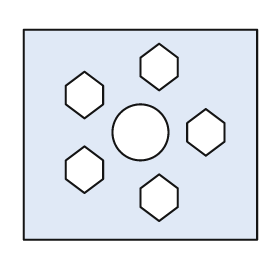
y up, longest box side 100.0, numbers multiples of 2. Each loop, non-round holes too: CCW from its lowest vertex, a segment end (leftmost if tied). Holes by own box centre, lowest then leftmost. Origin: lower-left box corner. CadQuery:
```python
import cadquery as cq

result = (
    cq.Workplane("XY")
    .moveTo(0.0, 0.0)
    .lineTo(100.0, 0.0)
    .lineTo(100.0, 90.0)
    .lineTo(0.0, 90.0)
    .close()
    .moveTo(58.0, 8.0)
    .lineTo(66.0, 14.0)
    .lineTo(66.0, 22.0)
    .lineTo(58.0, 28.0)
    .lineTo(50.0, 22.0)
    .lineTo(50.0, 14.0)
    .close()
    .moveTo(26.0, 20.0)
    .lineTo(34.0, 26.0)
    .lineTo(34.0, 34.0)
    .lineTo(26.0, 40.0)
    .lineTo(18.0, 34.0)
    .lineTo(18.0, 26.0)
    .close()
    .moveTo(50.0, 46.0)
    .circle(12.0)
    .moveTo(78.0, 36.0)
    .lineTo(86.0, 42.0)
    .lineTo(86.0, 50.0)
    .lineTo(78.0, 56.0)
    .lineTo(70.0, 50.0)
    .lineTo(70.0, 42.0)
    .close()
    .moveTo(26.0, 52.0)
    .lineTo(34.0, 58.0)
    .lineTo(34.0, 66.0)
    .lineTo(26.0, 72.0)
    .lineTo(18.0, 66.0)
    .lineTo(18.0, 58.0)
    .close()
    .moveTo(58.0, 64.0)
    .lineTo(66.0, 70.0)
    .lineTo(66.0, 78.0)
    .lineTo(58.0, 84.0)
    .lineTo(50.0, 78.0)
    .lineTo(50.0, 70.0)
    .close()
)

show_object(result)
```